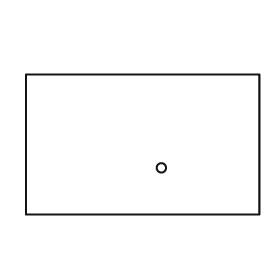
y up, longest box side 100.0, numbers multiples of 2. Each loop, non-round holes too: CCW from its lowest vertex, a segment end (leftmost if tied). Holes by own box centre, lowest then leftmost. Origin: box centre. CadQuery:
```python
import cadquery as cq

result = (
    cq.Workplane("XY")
    .moveTo(-50.0, -30.0)
    .lineTo(50.0, -30.0)
    .lineTo(50.0, 30.0)
    .lineTo(-50.0, 30.0)
    .close()
    .moveTo(8.0, -10.0)
    .circle(2.0)
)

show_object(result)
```